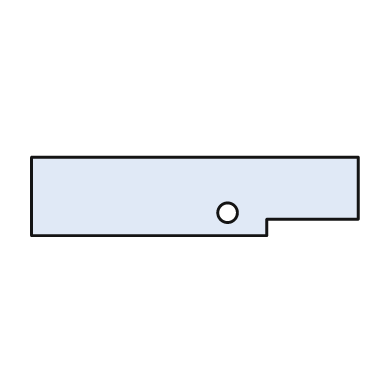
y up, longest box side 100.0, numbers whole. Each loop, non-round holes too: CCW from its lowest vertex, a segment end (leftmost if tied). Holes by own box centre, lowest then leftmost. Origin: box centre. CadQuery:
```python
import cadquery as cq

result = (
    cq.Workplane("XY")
    .moveTo(-50.0, -12.0)
    .lineTo(22.0, -12.0)
    .lineTo(22.0, -7.0)
    .lineTo(50.0, -7.0)
    .lineTo(50.0, 12.0)
    .lineTo(-50.0, 12.0)
    .close()
    .moveTo(10.0, -5.0)
    .circle(3.0)
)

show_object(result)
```